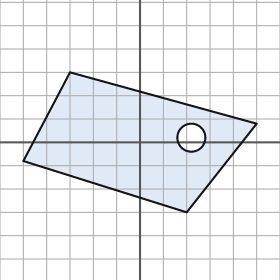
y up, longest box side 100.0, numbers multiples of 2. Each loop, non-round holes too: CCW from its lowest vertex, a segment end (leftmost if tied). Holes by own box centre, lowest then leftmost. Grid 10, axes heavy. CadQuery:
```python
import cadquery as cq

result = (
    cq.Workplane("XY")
    .moveTo(20.0, -30.0)
    .lineTo(50.0, 8.0)
    .lineTo(-30.0, 30.0)
    .lineTo(-50.0, -8.0)
    .close()
    .moveTo(22.0, 2.0)
    .circle(6.0)
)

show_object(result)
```